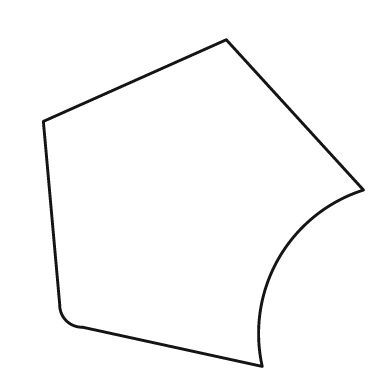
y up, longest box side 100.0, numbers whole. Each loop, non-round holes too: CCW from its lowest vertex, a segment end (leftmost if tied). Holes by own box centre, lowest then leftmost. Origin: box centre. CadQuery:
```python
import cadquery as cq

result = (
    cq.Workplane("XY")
    .moveTo(18.0, -50.0)
    .threePointArc((23.0, -17.0), (49.0, 4.0))
    .lineTo(7.0, 50.0)
    .lineTo(-49.0, 25.0)
    .lineTo(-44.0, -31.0)
    .threePointArc((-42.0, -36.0), (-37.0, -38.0))
    .close()
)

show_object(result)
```